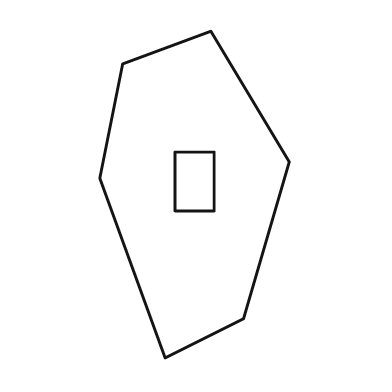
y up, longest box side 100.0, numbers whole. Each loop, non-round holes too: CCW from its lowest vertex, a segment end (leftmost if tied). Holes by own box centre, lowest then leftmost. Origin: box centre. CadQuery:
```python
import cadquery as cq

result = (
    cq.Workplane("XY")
    .moveTo(-9.0, -50.0)
    .lineTo(15.0, -38.0)
    .lineTo(29.0, 10.0)
    .lineTo(5.0, 50.0)
    .lineTo(-22.0, 40.0)
    .lineTo(-29.0, 5.0)
    .close()
    .moveTo(-6.0, -5.0)
    .lineTo(6.0, -5.0)
    .lineTo(6.0, 13.0)
    .lineTo(-6.0, 13.0)
    .close()
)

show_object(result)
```